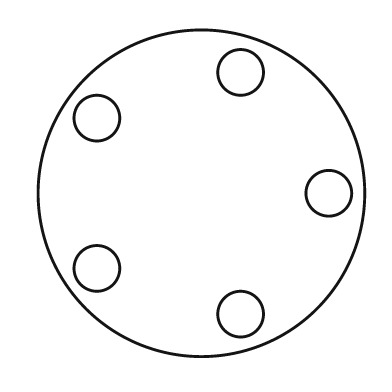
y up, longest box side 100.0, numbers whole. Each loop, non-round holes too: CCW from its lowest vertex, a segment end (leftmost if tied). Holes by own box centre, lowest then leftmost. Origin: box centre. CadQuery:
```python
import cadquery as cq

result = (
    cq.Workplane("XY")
    .moveTo(0.0, 0.0)
    .circle(50.0)
    .moveTo(12.0, -37.0)
    .circle(7.0)
    .moveTo(-32.0, -23.0)
    .circle(7.0)
    .moveTo(39.0, 0.0)
    .circle(7.0)
    .moveTo(-32.0, 23.0)
    .circle(7.0)
    .moveTo(12.0, 37.0)
    .circle(7.0)
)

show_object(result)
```